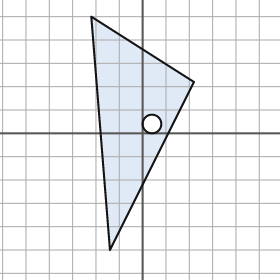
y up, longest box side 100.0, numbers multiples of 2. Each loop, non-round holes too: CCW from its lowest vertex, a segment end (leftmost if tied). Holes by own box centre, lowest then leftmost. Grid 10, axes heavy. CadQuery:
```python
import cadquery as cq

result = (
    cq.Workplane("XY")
    .moveTo(-14.0, -50.0)
    .lineTo(22.0, 22.0)
    .lineTo(-22.0, 50.0)
    .close()
    .moveTo(4.0, 4.0)
    .circle(4.0)
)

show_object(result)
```